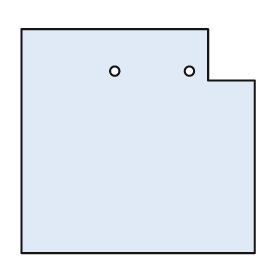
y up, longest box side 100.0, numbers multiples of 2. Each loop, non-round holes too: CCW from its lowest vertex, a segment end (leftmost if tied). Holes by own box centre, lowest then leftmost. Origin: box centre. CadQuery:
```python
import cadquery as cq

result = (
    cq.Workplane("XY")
    .moveTo(-50.0, -48.0)
    .lineTo(50.0, -48.0)
    .lineTo(50.0, 26.0)
    .lineTo(30.0, 26.0)
    .lineTo(30.0, 48.0)
    .lineTo(-50.0, 48.0)
    .close()
    .moveTo(-10.0, 30.0)
    .circle(2.0)
    .moveTo(22.0, 30.0)
    .circle(2.0)
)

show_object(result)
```